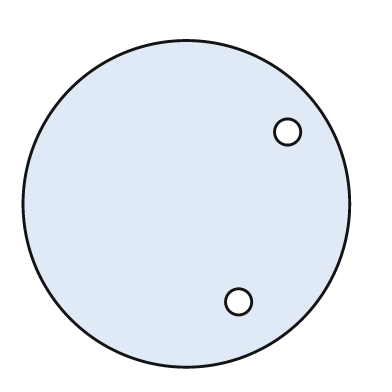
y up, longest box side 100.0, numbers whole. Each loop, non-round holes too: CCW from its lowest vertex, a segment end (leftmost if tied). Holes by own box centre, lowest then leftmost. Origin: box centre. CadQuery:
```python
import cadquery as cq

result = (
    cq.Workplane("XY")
    .moveTo(0.0, 0.0)
    .circle(50.0)
    .moveTo(16.0, -30.0)
    .circle(4.0)
    .moveTo(31.0, 22.0)
    .circle(4.0)
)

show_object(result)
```